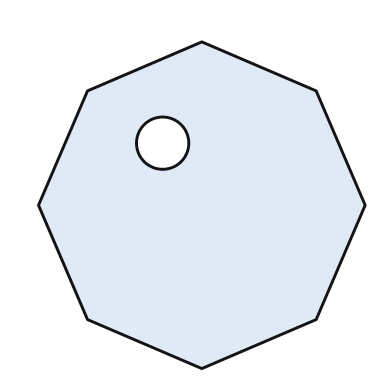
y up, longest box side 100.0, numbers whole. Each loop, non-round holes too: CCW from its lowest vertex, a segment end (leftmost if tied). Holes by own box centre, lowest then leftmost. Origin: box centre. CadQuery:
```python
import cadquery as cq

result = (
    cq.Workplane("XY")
    .moveTo(0.0, -50.0)
    .lineTo(35.0, -35.0)
    .lineTo(50.0, 0.0)
    .lineTo(35.0, 35.0)
    .lineTo(0.0, 50.0)
    .lineTo(-35.0, 35.0)
    .lineTo(-50.0, 0.0)
    .lineTo(-35.0, -35.0)
    .close()
    .moveTo(-12.0, 19.0)
    .circle(8.0)
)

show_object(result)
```